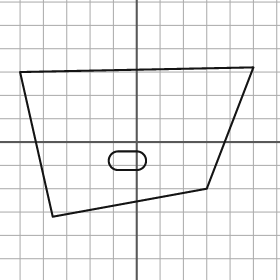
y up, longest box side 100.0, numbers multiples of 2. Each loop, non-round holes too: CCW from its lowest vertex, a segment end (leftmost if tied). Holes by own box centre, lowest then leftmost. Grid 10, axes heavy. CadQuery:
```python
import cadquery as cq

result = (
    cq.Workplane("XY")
    .moveTo(-36.0, -32.0)
    .lineTo(30.0, -20.0)
    .lineTo(50.0, 32.0)
    .lineTo(-50.0, 30.0)
    .close()
    .moveTo(-8.0, -12.0)
    .lineTo(0.0, -12.0)
    .threePointArc((4.0, -8.0), (0.0, -4.0))
    .lineTo(-8.0, -4.0)
    .threePointArc((-12.0, -8.0), (-8.0, -12.0))
    .close()
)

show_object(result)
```